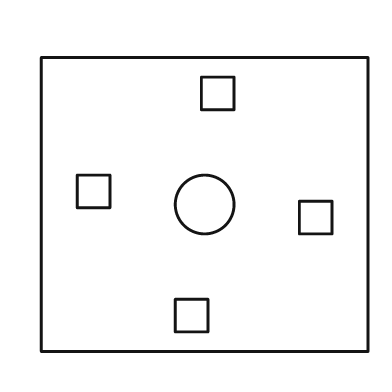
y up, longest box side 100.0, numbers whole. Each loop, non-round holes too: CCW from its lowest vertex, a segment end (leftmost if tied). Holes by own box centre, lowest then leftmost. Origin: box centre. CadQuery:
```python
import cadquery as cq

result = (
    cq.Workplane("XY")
    .moveTo(-50.0, -45.0)
    .lineTo(50.0, -45.0)
    .lineTo(50.0, 45.0)
    .lineTo(-50.0, 45.0)
    .close()
    .moveTo(-9.0, -39.0)
    .lineTo(1.0, -39.0)
    .lineTo(1.0, -29.0)
    .lineTo(-9.0, -29.0)
    .close()
    .moveTo(29.0, -9.0)
    .lineTo(39.0, -9.0)
    .lineTo(39.0, 1.0)
    .lineTo(29.0, 1.0)
    .close()
    .moveTo(0.0, 0.0)
    .circle(9.0)
    .moveTo(-39.0, -1.0)
    .lineTo(-29.0, -1.0)
    .lineTo(-29.0, 9.0)
    .lineTo(-39.0, 9.0)
    .close()
    .moveTo(-1.0, 29.0)
    .lineTo(9.0, 29.0)
    .lineTo(9.0, 39.0)
    .lineTo(-1.0, 39.0)
    .close()
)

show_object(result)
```